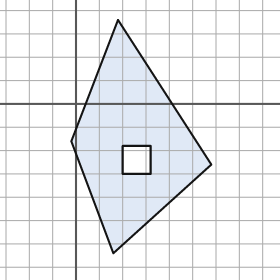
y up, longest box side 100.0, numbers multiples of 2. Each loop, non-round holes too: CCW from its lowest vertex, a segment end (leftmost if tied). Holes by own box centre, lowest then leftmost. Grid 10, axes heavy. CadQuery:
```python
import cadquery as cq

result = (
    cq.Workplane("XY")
    .moveTo(16.0, -64.0)
    .lineTo(58.0, -26.0)
    .lineTo(18.0, 36.0)
    .lineTo(-2.0, -16.0)
    .close()
    .moveTo(20.0, -30.0)
    .lineTo(32.0, -30.0)
    .lineTo(32.0, -18.0)
    .lineTo(20.0, -18.0)
    .close()
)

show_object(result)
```